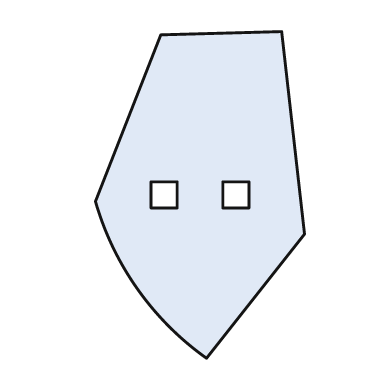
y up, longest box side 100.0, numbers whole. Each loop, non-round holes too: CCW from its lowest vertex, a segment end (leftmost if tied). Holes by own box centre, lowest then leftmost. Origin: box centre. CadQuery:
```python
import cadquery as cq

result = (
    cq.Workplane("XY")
    .moveTo(2.0, -50.0)
    .lineTo(32.0, -12.0)
    .lineTo(25.0, 50.0)
    .lineTo(-12.0, 49.0)
    .lineTo(-32.0, -2.0)
    .threePointArc((-19.0, -29.0), (2.0, -50.0))
    .close()
    .moveTo(-15.0, -4.0)
    .lineTo(-7.0, -4.0)
    .lineTo(-7.0, 4.0)
    .lineTo(-15.0, 4.0)
    .close()
    .moveTo(7.0, -4.0)
    .lineTo(15.0, -4.0)
    .lineTo(15.0, 4.0)
    .lineTo(7.0, 4.0)
    .close()
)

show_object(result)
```